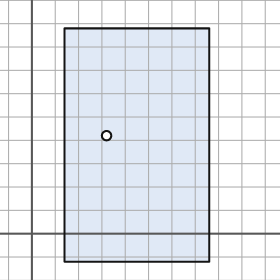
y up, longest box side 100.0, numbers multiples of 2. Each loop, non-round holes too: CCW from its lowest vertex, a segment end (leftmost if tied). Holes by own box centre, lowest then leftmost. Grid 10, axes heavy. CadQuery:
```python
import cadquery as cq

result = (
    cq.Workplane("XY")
    .moveTo(14.0, -12.0)
    .lineTo(76.0, -12.0)
    .lineTo(76.0, 88.0)
    .lineTo(14.0, 88.0)
    .close()
    .moveTo(32.0, 42.0)
    .circle(2.0)
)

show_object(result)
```